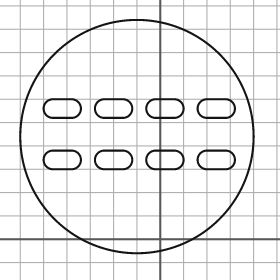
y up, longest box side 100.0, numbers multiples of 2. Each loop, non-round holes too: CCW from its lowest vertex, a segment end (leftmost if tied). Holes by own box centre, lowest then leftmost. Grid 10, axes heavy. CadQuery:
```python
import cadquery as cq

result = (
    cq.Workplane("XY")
    .moveTo(-10.0, 44.0)
    .circle(50.0)
    .moveTo(-46.0, 30.0)
    .lineTo(-38.0, 30.0)
    .threePointArc((-34.0, 34.0), (-38.0, 38.0))
    .lineTo(-46.0, 38.0)
    .threePointArc((-50.0, 34.0), (-46.0, 30.0))
    .close()
    .moveTo(-24.0, 30.0)
    .lineTo(-16.0, 30.0)
    .threePointArc((-12.0, 34.0), (-16.0, 38.0))
    .lineTo(-24.0, 38.0)
    .threePointArc((-28.0, 34.0), (-24.0, 30.0))
    .close()
    .moveTo(-2.0, 30.0)
    .lineTo(6.0, 30.0)
    .threePointArc((10.0, 34.0), (6.0, 38.0))
    .lineTo(-2.0, 38.0)
    .threePointArc((-6.0, 34.0), (-2.0, 30.0))
    .close()
    .moveTo(20.0, 30.0)
    .lineTo(28.0, 30.0)
    .threePointArc((32.0, 34.0), (28.0, 38.0))
    .lineTo(20.0, 38.0)
    .threePointArc((16.0, 34.0), (20.0, 30.0))
    .close()
    .moveTo(-46.0, 52.0)
    .lineTo(-38.0, 52.0)
    .threePointArc((-34.0, 56.0), (-38.0, 60.0))
    .lineTo(-46.0, 60.0)
    .threePointArc((-50.0, 56.0), (-46.0, 52.0))
    .close()
    .moveTo(-24.0, 52.0)
    .lineTo(-16.0, 52.0)
    .threePointArc((-12.0, 56.0), (-16.0, 60.0))
    .lineTo(-24.0, 60.0)
    .threePointArc((-28.0, 56.0), (-24.0, 52.0))
    .close()
    .moveTo(-2.0, 52.0)
    .lineTo(6.0, 52.0)
    .threePointArc((10.0, 56.0), (6.0, 60.0))
    .lineTo(-2.0, 60.0)
    .threePointArc((-6.0, 56.0), (-2.0, 52.0))
    .close()
    .moveTo(20.0, 52.0)
    .lineTo(28.0, 52.0)
    .threePointArc((32.0, 56.0), (28.0, 60.0))
    .lineTo(20.0, 60.0)
    .threePointArc((16.0, 56.0), (20.0, 52.0))
    .close()
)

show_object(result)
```